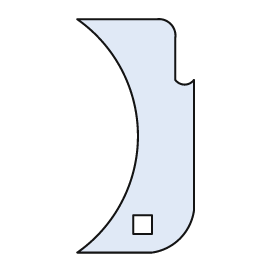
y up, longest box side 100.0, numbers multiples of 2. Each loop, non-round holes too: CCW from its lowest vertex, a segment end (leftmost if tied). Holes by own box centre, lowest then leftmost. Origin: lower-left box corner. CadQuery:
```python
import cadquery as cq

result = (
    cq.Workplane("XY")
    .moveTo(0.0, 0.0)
    .lineTo(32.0, 0.0)
    .threePointArc((44.0, 6.0), (50.0, 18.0))
    .lineTo(50.0, 74.0)
    .threePointArc((46.0, 72.0), (42.0, 74.0))
    .lineTo(42.0, 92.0)
    .threePointArc((40.0, 98.0), (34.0, 100.0))
    .lineTo(0.0, 100.0)
    .threePointArc((26.0, 50.0), (0.0, 0.0))
    .close()
    .moveTo(24.0, 8.0)
    .lineTo(32.0, 8.0)
    .lineTo(32.0, 16.0)
    .lineTo(24.0, 16.0)
    .close()
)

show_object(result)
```